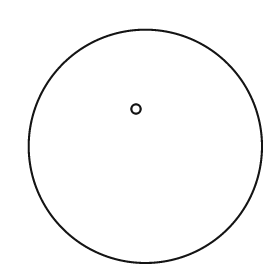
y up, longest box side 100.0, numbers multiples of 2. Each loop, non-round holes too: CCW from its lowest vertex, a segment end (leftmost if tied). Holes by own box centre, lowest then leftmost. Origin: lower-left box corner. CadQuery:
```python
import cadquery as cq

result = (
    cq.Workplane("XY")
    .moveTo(50.0, 50.0)
    .circle(50.0)
    .moveTo(46.0, 66.0)
    .circle(2.0)
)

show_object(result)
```